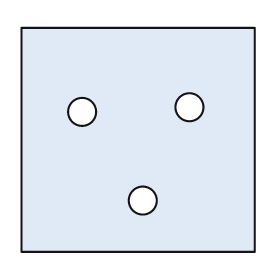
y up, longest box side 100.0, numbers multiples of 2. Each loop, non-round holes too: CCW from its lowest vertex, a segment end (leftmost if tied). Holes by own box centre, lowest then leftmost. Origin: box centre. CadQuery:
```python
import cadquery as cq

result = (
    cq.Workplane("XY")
    .moveTo(-50.0, -48.0)
    .lineTo(50.0, -48.0)
    .lineTo(50.0, 48.0)
    .lineTo(-50.0, 48.0)
    .close()
    .moveTo(2.0, -26.0)
    .circle(6.0)
    .moveTo(-24.0, 12.0)
    .circle(6.0)
    .moveTo(22.0, 14.0)
    .circle(6.0)
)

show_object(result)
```